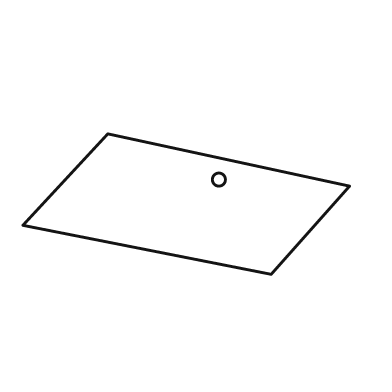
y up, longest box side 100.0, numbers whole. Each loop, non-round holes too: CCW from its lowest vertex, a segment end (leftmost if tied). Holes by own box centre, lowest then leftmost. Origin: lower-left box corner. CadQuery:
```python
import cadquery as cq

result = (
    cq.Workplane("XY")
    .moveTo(76.0, 0.0)
    .lineTo(100.0, 27.0)
    .lineTo(26.0, 43.0)
    .lineTo(0.0, 15.0)
    .close()
    .moveTo(60.0, 29.0)
    .circle(2.0)
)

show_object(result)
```